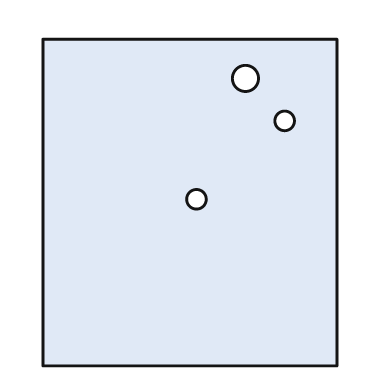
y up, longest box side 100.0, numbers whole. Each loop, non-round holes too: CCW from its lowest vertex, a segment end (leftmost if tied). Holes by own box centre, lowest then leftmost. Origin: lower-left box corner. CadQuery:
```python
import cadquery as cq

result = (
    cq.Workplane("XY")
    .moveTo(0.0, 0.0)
    .lineTo(90.0, 0.0)
    .lineTo(90.0, 100.0)
    .lineTo(0.0, 100.0)
    .close()
    .moveTo(47.0, 51.0)
    .circle(3.0)
    .moveTo(74.0, 75.0)
    .circle(3.0)
    .moveTo(62.0, 88.0)
    .circle(4.0)
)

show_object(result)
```